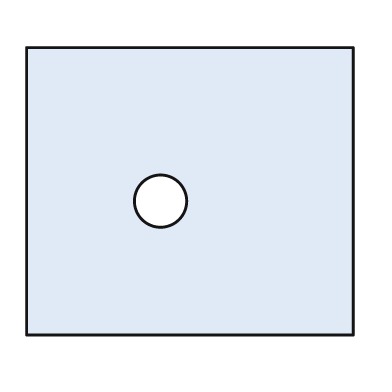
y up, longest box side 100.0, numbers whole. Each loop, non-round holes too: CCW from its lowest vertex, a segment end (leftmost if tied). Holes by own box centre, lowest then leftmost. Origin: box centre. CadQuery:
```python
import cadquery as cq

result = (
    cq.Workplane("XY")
    .moveTo(-50.0, -44.0)
    .lineTo(50.0, -44.0)
    .lineTo(50.0, 44.0)
    .lineTo(-50.0, 44.0)
    .close()
    .moveTo(-9.0, -3.0)
    .circle(8.0)
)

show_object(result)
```